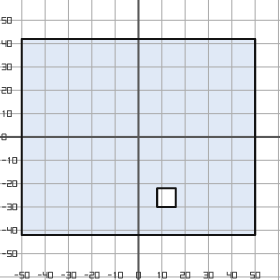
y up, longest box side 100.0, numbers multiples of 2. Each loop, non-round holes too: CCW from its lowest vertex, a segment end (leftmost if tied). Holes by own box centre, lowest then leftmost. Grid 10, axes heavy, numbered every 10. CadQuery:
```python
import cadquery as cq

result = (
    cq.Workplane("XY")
    .moveTo(-50.0, -42.0)
    .lineTo(50.0, -42.0)
    .lineTo(50.0, 42.0)
    .lineTo(-50.0, 42.0)
    .close()
    .moveTo(8.0, -30.0)
    .lineTo(16.0, -30.0)
    .lineTo(16.0, -22.0)
    .lineTo(8.0, -22.0)
    .close()
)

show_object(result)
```